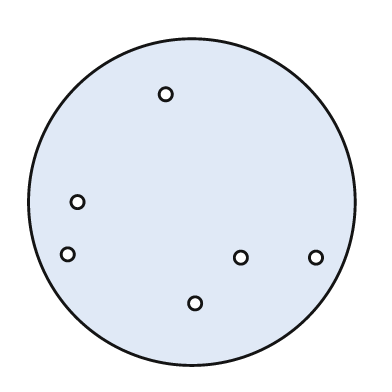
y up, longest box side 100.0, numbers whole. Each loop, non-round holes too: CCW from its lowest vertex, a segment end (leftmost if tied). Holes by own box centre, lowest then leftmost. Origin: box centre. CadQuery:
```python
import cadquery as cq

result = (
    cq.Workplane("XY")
    .moveTo(0.0, 0.0)
    .circle(50.0)
    .moveTo(1.0, -31.0)
    .circle(2.0)
    .moveTo(15.0, -17.0)
    .circle(2.0)
    .moveTo(38.0, -17.0)
    .circle(2.0)
    .moveTo(-38.0, -16.0)
    .circle(2.0)
    .moveTo(-35.0, 0.0)
    .circle(2.0)
    .moveTo(-8.0, 33.0)
    .circle(2.0)
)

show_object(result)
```